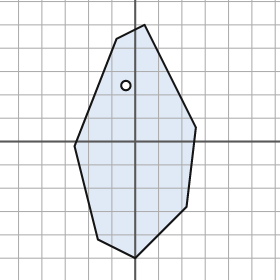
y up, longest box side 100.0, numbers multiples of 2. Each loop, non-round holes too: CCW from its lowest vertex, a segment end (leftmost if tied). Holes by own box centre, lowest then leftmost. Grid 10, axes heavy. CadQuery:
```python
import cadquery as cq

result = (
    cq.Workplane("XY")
    .moveTo(0.0, -50.0)
    .lineTo(22.0, -28.0)
    .lineTo(26.0, 6.0)
    .lineTo(4.0, 50.0)
    .lineTo(-8.0, 44.0)
    .lineTo(-26.0, -2.0)
    .lineTo(-16.0, -42.0)
    .close()
    .moveTo(-4.0, 24.0)
    .circle(2.0)
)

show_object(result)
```